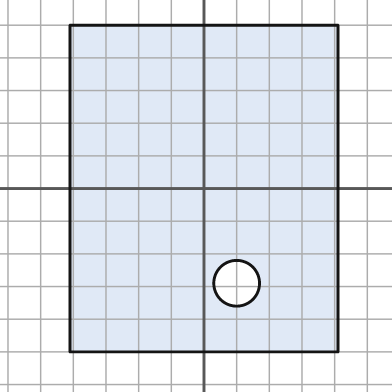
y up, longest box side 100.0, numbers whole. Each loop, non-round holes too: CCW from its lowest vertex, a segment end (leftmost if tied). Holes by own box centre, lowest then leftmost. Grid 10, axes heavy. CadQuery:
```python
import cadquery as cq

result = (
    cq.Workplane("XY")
    .moveTo(-41.0, -50.0)
    .lineTo(41.0, -50.0)
    .lineTo(41.0, 50.0)
    .lineTo(-41.0, 50.0)
    .close()
    .moveTo(10.0, -29.0)
    .circle(7.0)
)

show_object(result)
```